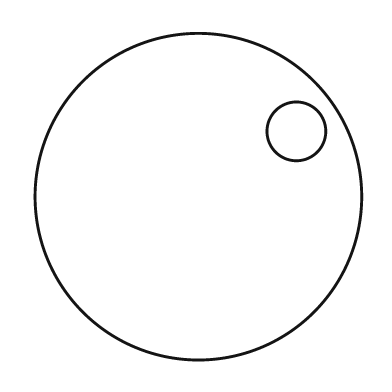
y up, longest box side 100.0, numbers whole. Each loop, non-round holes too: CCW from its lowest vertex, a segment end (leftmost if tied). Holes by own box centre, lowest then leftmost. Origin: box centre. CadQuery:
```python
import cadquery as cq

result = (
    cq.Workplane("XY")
    .moveTo(0.0, 0.0)
    .circle(50.0)
    .moveTo(30.0, 20.0)
    .circle(9.0)
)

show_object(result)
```